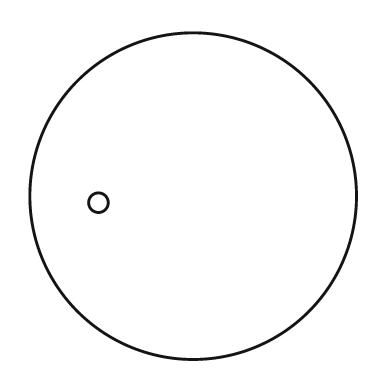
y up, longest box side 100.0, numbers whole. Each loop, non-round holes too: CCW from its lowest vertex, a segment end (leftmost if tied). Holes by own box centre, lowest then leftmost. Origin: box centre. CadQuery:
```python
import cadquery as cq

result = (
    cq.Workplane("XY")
    .moveTo(0.0, 0.0)
    .circle(50.0)
    .moveTo(-29.0, -2.0)
    .circle(3.0)
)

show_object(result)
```